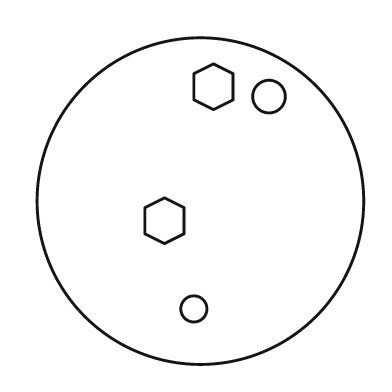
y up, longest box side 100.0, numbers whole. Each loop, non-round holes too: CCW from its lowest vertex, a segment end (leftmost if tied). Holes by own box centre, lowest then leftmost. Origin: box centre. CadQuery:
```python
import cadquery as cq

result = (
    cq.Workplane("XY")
    .moveTo(0.0, 0.0)
    .circle(50.0)
    .moveTo(-2.0, -33.0)
    .circle(4.0)
    .moveTo(-11.0, -13.0)
    .lineTo(-5.0, -10.0)
    .lineTo(-5.0, -2.0)
    .lineTo(-11.0, 1.0)
    .lineTo(-17.0, -2.0)
    .lineTo(-17.0, -10.0)
    .close()
    .moveTo(21.0, 32.0)
    .circle(5.0)
    .moveTo(4.0, 28.0)
    .lineTo(10.0, 31.0)
    .lineTo(10.0, 39.0)
    .lineTo(4.0, 42.0)
    .lineTo(-2.0, 39.0)
    .lineTo(-2.0, 31.0)
    .close()
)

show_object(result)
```